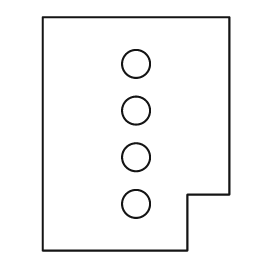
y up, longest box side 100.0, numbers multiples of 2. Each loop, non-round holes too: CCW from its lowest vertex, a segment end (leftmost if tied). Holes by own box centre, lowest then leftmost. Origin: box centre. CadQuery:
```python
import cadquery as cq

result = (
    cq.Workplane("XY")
    .moveTo(-40.0, -50.0)
    .lineTo(22.0, -50.0)
    .lineTo(22.0, -26.0)
    .lineTo(40.0, -26.0)
    .lineTo(40.0, 50.0)
    .lineTo(-40.0, 50.0)
    .close()
    .moveTo(0.0, -30.0)
    .circle(6.0)
    .moveTo(0.0, -10.0)
    .circle(6.0)
    .moveTo(0.0, 10.0)
    .circle(6.0)
    .moveTo(0.0, 30.0)
    .circle(6.0)
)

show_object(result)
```